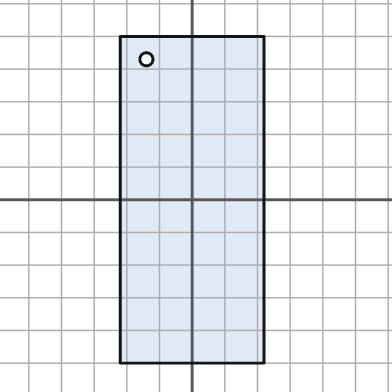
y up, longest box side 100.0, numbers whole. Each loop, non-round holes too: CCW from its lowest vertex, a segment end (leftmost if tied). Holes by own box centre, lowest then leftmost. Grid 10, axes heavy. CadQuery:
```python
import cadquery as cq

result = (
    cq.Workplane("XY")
    .moveTo(-22.0, -50.0)
    .lineTo(22.0, -50.0)
    .lineTo(22.0, 50.0)
    .lineTo(-22.0, 50.0)
    .close()
    .moveTo(-14.0, 43.0)
    .circle(2.0)
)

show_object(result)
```